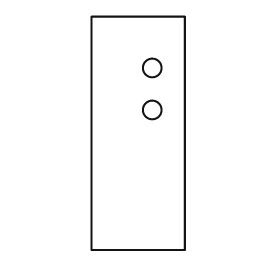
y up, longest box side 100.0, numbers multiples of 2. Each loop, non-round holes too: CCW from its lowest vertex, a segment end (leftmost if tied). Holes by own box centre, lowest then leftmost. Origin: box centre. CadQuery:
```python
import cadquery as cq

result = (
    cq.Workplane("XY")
    .moveTo(-20.0, -50.0)
    .lineTo(20.0, -50.0)
    .lineTo(20.0, 50.0)
    .lineTo(-20.0, 50.0)
    .close()
    .moveTo(6.0, 10.0)
    .circle(4.0)
    .moveTo(6.0, 28.0)
    .circle(4.0)
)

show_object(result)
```